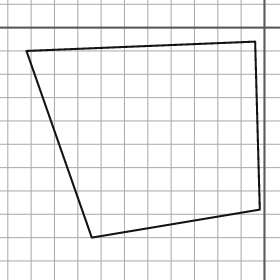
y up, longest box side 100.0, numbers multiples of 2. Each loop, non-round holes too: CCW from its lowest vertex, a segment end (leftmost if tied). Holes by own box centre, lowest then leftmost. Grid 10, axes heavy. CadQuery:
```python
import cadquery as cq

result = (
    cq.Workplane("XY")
    .moveTo(-74.0, -90.0)
    .lineTo(-2.0, -78.0)
    .lineTo(-4.0, -6.0)
    .lineTo(-102.0, -10.0)
    .close()
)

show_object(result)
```